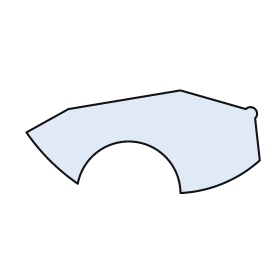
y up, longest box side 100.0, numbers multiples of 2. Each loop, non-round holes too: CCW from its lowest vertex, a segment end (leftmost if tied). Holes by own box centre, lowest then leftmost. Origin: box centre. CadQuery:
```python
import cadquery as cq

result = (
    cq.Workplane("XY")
    .moveTo(16.0, -22.0)
    .threePointArc((34.0, -18.0), (50.0, -8.0))
    .lineTo(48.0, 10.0)
    .threePointArc((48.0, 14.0), (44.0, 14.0))
    .lineTo(16.0, 22.0)
    .lineTo(-32.0, 14.0)
    .lineTo(-50.0, 4.0)
    .threePointArc((-40.0, -8.0), (-28.0, -18.0))
    .threePointArc((-4.0, 0.0), (16.0, -22.0))
    .close()
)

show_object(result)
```